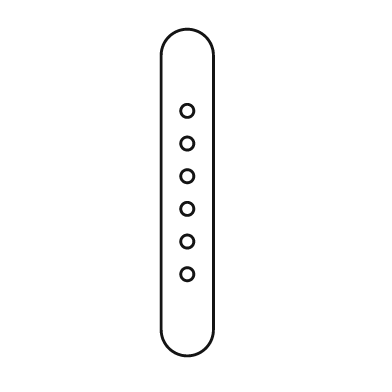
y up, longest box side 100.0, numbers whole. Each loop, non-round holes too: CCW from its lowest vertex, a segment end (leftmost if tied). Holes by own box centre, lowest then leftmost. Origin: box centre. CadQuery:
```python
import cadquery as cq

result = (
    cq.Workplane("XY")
    .moveTo(-8.0, -42.0)
    .threePointArc((0.0, -50.0), (8.0, -42.0))
    .lineTo(8.0, 42.0)
    .threePointArc((0.0, 50.0), (-8.0, 42.0))
    .close()
    .moveTo(0.0, -25.0)
    .circle(2.0)
    .moveTo(0.0, -15.0)
    .circle(2.0)
    .moveTo(0.0, -5.0)
    .circle(2.0)
    .moveTo(0.0, 5.0)
    .circle(2.0)
    .moveTo(0.0, 15.0)
    .circle(2.0)
    .moveTo(0.0, 25.0)
    .circle(2.0)
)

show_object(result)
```